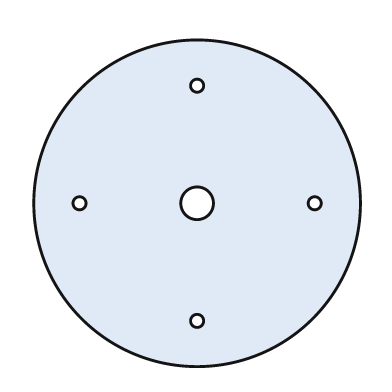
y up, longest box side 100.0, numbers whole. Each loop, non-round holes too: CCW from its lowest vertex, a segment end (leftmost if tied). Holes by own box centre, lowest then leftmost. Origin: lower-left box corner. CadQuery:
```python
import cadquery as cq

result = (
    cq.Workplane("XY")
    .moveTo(50.0, 50.0)
    .circle(50.0)
    .moveTo(50.0, 14.0)
    .circle(2.0)
    .moveTo(14.0, 50.0)
    .circle(2.0)
    .moveTo(50.0, 50.0)
    .circle(5.0)
    .moveTo(86.0, 50.0)
    .circle(2.0)
    .moveTo(50.0, 86.0)
    .circle(2.0)
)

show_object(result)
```